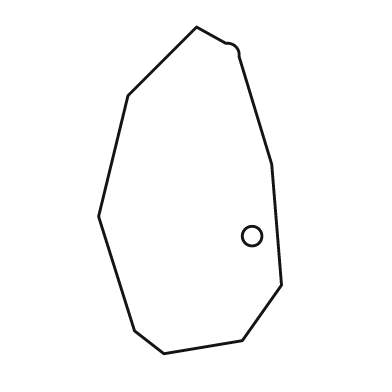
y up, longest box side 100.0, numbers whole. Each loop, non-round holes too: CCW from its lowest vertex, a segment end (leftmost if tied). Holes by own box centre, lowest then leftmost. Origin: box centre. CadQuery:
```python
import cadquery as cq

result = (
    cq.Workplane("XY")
    .moveTo(-8.0, -50.0)
    .lineTo(16.0, -46.0)
    .lineTo(28.0, -29.0)
    .lineTo(25.0, 8.0)
    .lineTo(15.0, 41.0)
    .threePointArc((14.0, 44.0), (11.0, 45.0))
    .lineTo(2.0, 50.0)
    .lineTo(-19.0, 29.0)
    .lineTo(-28.0, -8.0)
    .lineTo(-17.0, -43.0)
    .close()
    .moveTo(19.0, -14.0)
    .circle(3.0)
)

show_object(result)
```